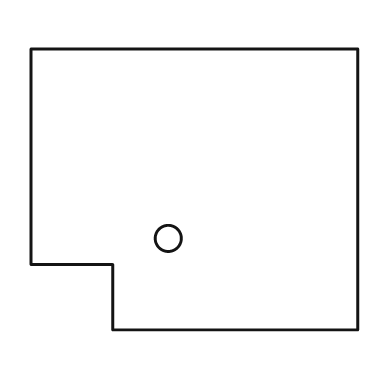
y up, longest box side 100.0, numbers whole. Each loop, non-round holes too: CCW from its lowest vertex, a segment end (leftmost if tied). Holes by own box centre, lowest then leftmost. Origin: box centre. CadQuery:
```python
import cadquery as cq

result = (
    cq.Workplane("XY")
    .moveTo(-25.0, -43.0)
    .lineTo(50.0, -43.0)
    .lineTo(50.0, 43.0)
    .lineTo(-50.0, 43.0)
    .lineTo(-50.0, -23.0)
    .lineTo(-25.0, -23.0)
    .close()
    .moveTo(-8.0, -15.0)
    .circle(4.0)
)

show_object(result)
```